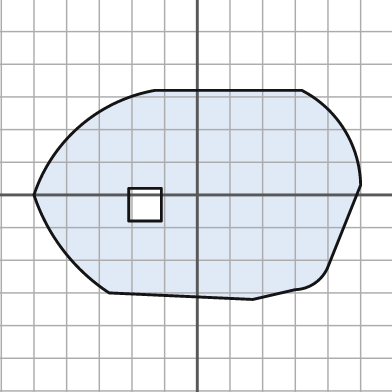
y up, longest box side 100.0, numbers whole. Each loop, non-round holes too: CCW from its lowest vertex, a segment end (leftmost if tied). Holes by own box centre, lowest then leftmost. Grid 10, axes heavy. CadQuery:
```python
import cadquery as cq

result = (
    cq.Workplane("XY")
    .moveTo(17.0, -32.0)
    .lineTo(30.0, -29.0)
    .threePointArc((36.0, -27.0), (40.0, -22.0))
    .lineTo(50.0, 3.0)
    .threePointArc((45.0, 20.0), (32.0, 32.0))
    .lineTo(-13.0, 32.0)
    .threePointArc((-36.0, 21.0), (-50.0, 0.0))
    .threePointArc((-41.0, -17.0), (-27.0, -30.0))
    .close()
    .moveTo(-21.0, -8.0)
    .lineTo(-11.0, -8.0)
    .lineTo(-11.0, 2.0)
    .lineTo(-21.0, 2.0)
    .close()
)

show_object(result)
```